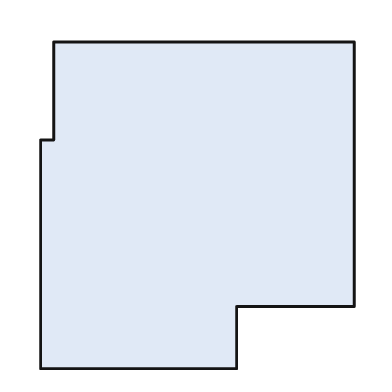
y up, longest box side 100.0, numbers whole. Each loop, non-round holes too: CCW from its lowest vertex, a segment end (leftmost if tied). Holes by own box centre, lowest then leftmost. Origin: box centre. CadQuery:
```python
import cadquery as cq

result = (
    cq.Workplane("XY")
    .moveTo(-48.0, -50.0)
    .lineTo(12.0, -50.0)
    .lineTo(12.0, -31.0)
    .lineTo(48.0, -31.0)
    .lineTo(48.0, 50.0)
    .lineTo(-44.0, 50.0)
    .lineTo(-44.0, 20.0)
    .lineTo(-48.0, 20.0)
    .close()
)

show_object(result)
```